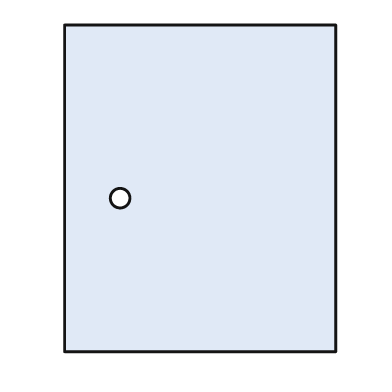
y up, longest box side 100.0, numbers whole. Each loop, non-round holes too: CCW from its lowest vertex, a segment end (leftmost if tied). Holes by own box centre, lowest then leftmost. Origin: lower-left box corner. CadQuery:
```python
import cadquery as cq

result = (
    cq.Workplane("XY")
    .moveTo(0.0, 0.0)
    .lineTo(83.0, 0.0)
    .lineTo(83.0, 100.0)
    .lineTo(0.0, 100.0)
    .close()
    .moveTo(17.0, 47.0)
    .circle(3.0)
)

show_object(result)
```